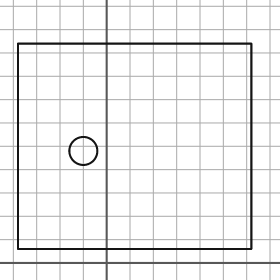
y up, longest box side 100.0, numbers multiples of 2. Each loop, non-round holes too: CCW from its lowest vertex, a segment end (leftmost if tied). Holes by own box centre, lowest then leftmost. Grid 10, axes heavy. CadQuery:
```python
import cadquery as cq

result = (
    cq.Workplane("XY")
    .moveTo(-38.0, 6.0)
    .lineTo(62.0, 6.0)
    .lineTo(62.0, 94.0)
    .lineTo(-38.0, 94.0)
    .close()
    .moveTo(-10.0, 48.0)
    .circle(6.0)
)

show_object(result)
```